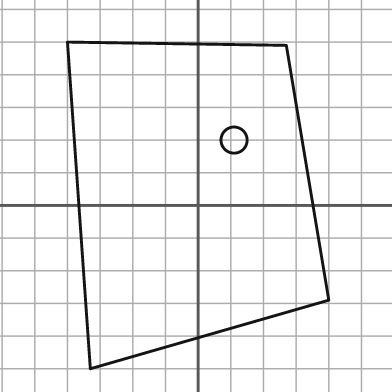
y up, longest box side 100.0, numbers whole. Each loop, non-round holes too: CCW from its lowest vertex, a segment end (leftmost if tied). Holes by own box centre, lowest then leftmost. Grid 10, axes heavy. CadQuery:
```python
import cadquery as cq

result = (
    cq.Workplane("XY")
    .moveTo(-33.0, -50.0)
    .lineTo(40.0, -29.0)
    .lineTo(27.0, 49.0)
    .lineTo(-40.0, 50.0)
    .close()
    .moveTo(11.0, 20.0)
    .circle(4.0)
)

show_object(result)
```